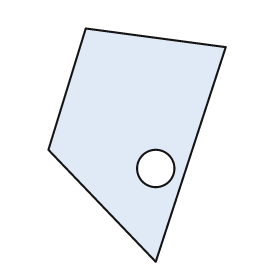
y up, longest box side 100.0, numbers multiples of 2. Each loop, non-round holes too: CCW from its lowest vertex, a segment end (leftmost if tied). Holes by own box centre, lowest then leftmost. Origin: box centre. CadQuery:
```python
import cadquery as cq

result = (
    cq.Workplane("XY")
    .moveTo(8.0, -50.0)
    .lineTo(38.0, 42.0)
    .lineTo(-22.0, 50.0)
    .lineTo(-38.0, -2.0)
    .close()
    .moveTo(8.0, -10.0)
    .circle(8.0)
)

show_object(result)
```